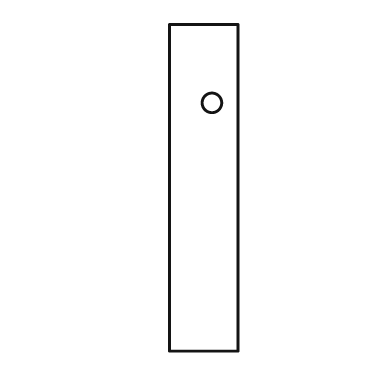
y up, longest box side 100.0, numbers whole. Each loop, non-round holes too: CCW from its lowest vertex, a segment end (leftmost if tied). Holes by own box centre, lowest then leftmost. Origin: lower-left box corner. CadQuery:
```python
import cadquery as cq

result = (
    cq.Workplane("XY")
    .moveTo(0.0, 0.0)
    .lineTo(21.0, 0.0)
    .lineTo(21.0, 100.0)
    .lineTo(0.0, 100.0)
    .close()
    .moveTo(13.0, 76.0)
    .circle(3.0)
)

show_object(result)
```